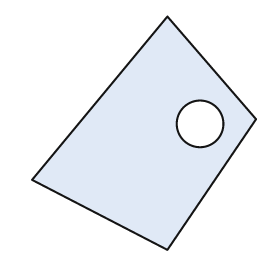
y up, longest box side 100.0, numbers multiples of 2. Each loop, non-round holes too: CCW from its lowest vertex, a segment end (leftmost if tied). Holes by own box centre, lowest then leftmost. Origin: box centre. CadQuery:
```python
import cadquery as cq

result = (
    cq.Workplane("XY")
    .moveTo(10.0, -50.0)
    .lineTo(48.0, 6.0)
    .lineTo(10.0, 50.0)
    .lineTo(-48.0, -20.0)
    .close()
    .moveTo(24.0, 4.0)
    .circle(10.0)
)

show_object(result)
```